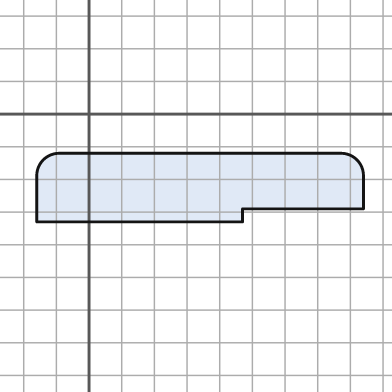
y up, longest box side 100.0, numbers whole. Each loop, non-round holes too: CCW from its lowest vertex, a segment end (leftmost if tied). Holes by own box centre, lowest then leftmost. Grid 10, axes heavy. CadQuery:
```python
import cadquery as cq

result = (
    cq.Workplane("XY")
    .moveTo(-16.0, -33.0)
    .lineTo(47.0, -33.0)
    .lineTo(47.0, -29.0)
    .lineTo(84.0, -29.0)
    .lineTo(84.0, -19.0)
    .threePointArc((82.0, -14.0), (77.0, -12.0))
    .lineTo(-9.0, -12.0)
    .threePointArc((-14.0, -14.0), (-16.0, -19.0))
    .close()
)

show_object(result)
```